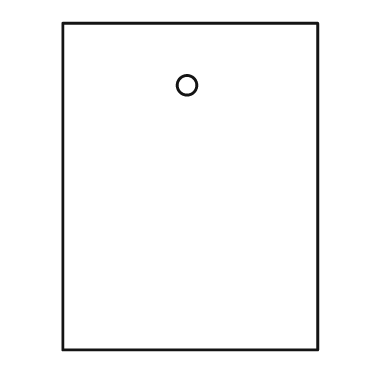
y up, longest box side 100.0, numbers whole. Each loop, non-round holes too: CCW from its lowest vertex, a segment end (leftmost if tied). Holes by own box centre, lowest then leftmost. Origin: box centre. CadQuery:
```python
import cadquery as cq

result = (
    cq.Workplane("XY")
    .moveTo(-39.0, -50.0)
    .lineTo(39.0, -50.0)
    .lineTo(39.0, 50.0)
    .lineTo(-39.0, 50.0)
    .close()
    .moveTo(-1.0, 31.0)
    .circle(3.0)
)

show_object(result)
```